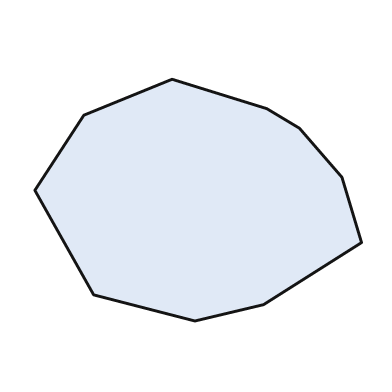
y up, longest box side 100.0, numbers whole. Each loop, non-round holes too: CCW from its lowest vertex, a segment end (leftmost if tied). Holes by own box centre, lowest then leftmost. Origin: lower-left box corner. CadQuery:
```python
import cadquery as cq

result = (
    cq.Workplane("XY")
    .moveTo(49.0, 0.0)
    .lineTo(70.0, 5.0)
    .lineTo(100.0, 24.0)
    .lineTo(94.0, 44.0)
    .lineTo(81.0, 59.0)
    .lineTo(71.0, 65.0)
    .lineTo(42.0, 74.0)
    .lineTo(15.0, 63.0)
    .lineTo(0.0, 40.0)
    .lineTo(18.0, 8.0)
    .close()
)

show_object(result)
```